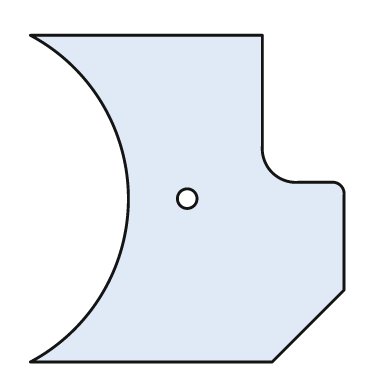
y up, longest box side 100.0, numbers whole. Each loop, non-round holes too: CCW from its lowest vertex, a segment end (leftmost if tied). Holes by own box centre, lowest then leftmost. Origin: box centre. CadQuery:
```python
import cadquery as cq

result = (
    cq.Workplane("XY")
    .moveTo(-48.0, -50.0)
    .lineTo(26.0, -50.0)
    .lineTo(48.0, -28.0)
    .lineTo(48.0, 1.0)
    .threePointArc((47.0, 4.0), (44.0, 5.0))
    .lineTo(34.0, 5.0)
    .threePointArc((26.0, 8.0), (23.0, 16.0))
    .lineTo(23.0, 50.0)
    .lineTo(-48.0, 50.0)
    .threePointArc((-18.0, 0.0), (-48.0, -50.0))
    .close()
    .moveTo(0.0, 0.0)
    .circle(3.0)
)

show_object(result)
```